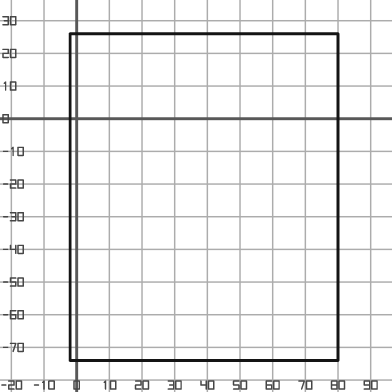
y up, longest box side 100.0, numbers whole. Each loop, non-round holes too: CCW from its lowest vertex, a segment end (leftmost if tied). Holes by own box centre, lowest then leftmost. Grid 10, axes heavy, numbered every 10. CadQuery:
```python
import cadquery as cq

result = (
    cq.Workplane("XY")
    .moveTo(-2.0, -74.0)
    .lineTo(80.0, -74.0)
    .lineTo(80.0, 26.0)
    .lineTo(-2.0, 26.0)
    .close()
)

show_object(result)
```